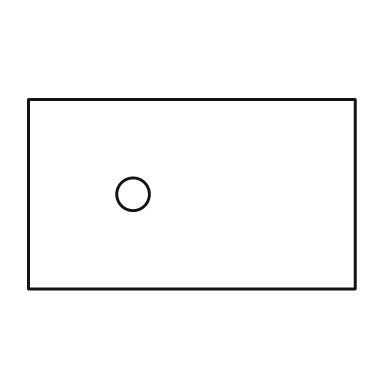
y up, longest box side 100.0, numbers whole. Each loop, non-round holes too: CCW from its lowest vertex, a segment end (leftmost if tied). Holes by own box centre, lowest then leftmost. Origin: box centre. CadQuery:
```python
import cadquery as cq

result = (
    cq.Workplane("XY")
    .moveTo(-50.0, -29.0)
    .lineTo(50.0, -29.0)
    .lineTo(50.0, 29.0)
    .lineTo(-50.0, 29.0)
    .close()
    .moveTo(-18.0, 0.0)
    .circle(5.0)
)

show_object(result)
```